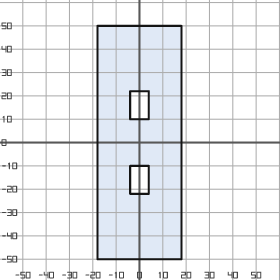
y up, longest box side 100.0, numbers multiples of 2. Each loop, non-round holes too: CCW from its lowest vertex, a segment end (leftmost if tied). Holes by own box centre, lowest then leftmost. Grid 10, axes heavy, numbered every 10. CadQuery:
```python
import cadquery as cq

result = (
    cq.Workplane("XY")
    .moveTo(-18.0, -50.0)
    .lineTo(18.0, -50.0)
    .lineTo(18.0, 50.0)
    .lineTo(-18.0, 50.0)
    .close()
    .moveTo(-4.0, -22.0)
    .lineTo(4.0, -22.0)
    .lineTo(4.0, -10.0)
    .lineTo(-4.0, -10.0)
    .close()
    .moveTo(-4.0, 10.0)
    .lineTo(4.0, 10.0)
    .lineTo(4.0, 22.0)
    .lineTo(-4.0, 22.0)
    .close()
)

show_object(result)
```